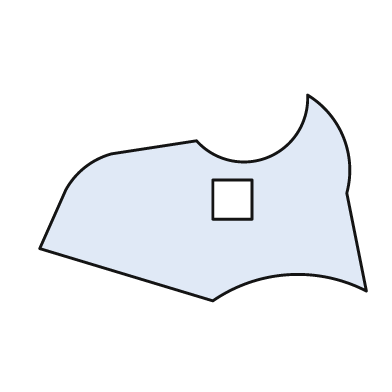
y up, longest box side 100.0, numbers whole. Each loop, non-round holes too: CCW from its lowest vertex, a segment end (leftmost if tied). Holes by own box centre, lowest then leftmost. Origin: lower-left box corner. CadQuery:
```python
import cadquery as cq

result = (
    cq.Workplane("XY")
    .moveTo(53.0, 0.0)
    .threePointArc((76.0, 8.0), (100.0, 3.0))
    .lineTo(94.0, 33.0)
    .threePointArc((93.0, 50.0), (82.0, 63.0))
    .threePointArc((70.0, 44.0), (48.0, 49.0))
    .lineTo(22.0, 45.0)
    .threePointArc((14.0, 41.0), (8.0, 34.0))
    .lineTo(0.0, 16.0)
    .close()
    .moveTo(53.0, 25.0)
    .lineTo(65.0, 25.0)
    .lineTo(65.0, 37.0)
    .lineTo(53.0, 37.0)
    .close()
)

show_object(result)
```